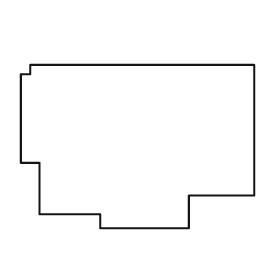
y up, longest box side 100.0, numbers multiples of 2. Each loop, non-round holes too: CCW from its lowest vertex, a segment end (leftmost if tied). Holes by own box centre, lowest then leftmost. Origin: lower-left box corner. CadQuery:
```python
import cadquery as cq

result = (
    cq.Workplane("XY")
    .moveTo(34.0, 0.0)
    .lineTo(72.0, 0.0)
    .lineTo(72.0, 14.0)
    .lineTo(100.0, 14.0)
    .lineTo(100.0, 70.0)
    .lineTo(4.0, 70.0)
    .lineTo(4.0, 66.0)
    .lineTo(0.0, 66.0)
    .lineTo(0.0, 28.0)
    .lineTo(8.0, 28.0)
    .lineTo(8.0, 6.0)
    .lineTo(34.0, 6.0)
    .close()
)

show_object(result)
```